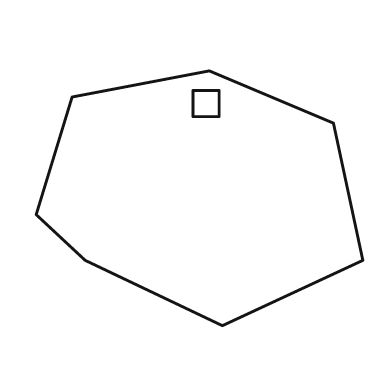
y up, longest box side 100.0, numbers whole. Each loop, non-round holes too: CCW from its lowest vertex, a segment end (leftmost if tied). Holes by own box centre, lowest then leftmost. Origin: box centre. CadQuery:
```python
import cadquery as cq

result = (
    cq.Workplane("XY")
    .moveTo(7.0, -39.0)
    .lineTo(50.0, -19.0)
    .lineTo(41.0, 23.0)
    .lineTo(3.0, 39.0)
    .lineTo(-39.0, 31.0)
    .lineTo(-50.0, -5.0)
    .lineTo(-35.0, -19.0)
    .close()
    .moveTo(-2.0, 25.0)
    .lineTo(6.0, 25.0)
    .lineTo(6.0, 33.0)
    .lineTo(-2.0, 33.0)
    .close()
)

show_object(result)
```